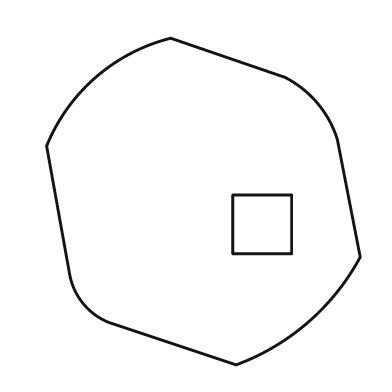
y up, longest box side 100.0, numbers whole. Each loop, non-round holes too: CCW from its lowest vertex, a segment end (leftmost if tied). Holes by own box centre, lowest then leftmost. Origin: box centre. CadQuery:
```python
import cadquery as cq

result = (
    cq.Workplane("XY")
    .moveTo(10.0, -50.0)
    .threePointArc((32.0, -37.0), (48.0, -17.0))
    .lineTo(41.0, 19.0)
    .threePointArc((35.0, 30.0), (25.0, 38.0))
    .lineTo(-10.0, 50.0)
    .threePointArc((-33.0, 38.0), (-48.0, 17.0))
    .lineTo(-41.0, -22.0)
    .threePointArc((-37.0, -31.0), (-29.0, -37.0))
    .close()
    .moveTo(9.0, -16.0)
    .lineTo(27.0, -16.0)
    .lineTo(27.0, 2.0)
    .lineTo(9.0, 2.0)
    .close()
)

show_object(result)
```